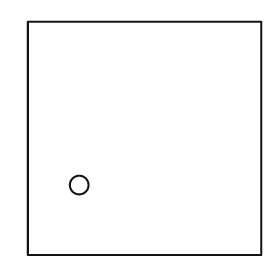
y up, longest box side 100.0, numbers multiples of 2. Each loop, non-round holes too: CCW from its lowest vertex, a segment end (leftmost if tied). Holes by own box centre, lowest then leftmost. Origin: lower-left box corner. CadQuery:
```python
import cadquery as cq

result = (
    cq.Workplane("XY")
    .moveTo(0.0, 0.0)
    .lineTo(100.0, 0.0)
    .lineTo(100.0, 100.0)
    .lineTo(0.0, 100.0)
    .close()
    .moveTo(22.0, 30.0)
    .circle(4.0)
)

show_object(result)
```